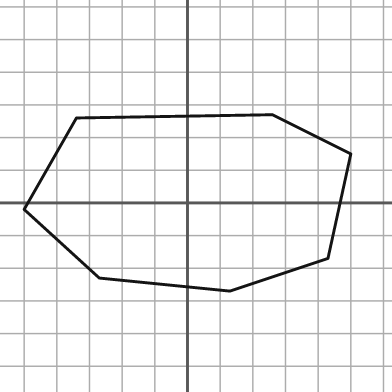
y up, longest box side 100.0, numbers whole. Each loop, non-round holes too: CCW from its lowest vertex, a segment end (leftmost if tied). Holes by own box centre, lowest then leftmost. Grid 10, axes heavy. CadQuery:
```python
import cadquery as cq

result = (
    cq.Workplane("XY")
    .moveTo(13.0, -27.0)
    .lineTo(43.0, -17.0)
    .lineTo(50.0, 15.0)
    .lineTo(26.0, 27.0)
    .lineTo(-34.0, 26.0)
    .lineTo(-50.0, -2.0)
    .lineTo(-27.0, -23.0)
    .close()
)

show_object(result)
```